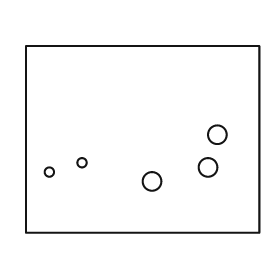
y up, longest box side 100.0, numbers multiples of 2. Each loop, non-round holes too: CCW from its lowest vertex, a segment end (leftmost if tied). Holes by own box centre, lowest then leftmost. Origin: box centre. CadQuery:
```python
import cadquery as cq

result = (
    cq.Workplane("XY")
    .moveTo(-50.0, -40.0)
    .lineTo(50.0, -40.0)
    .lineTo(50.0, 40.0)
    .lineTo(-50.0, 40.0)
    .close()
    .moveTo(4.0, -18.0)
    .circle(4.0)
    .moveTo(-40.0, -14.0)
    .circle(2.0)
    .moveTo(28.0, -12.0)
    .circle(4.0)
    .moveTo(-26.0, -10.0)
    .circle(2.0)
    .moveTo(32.0, 2.0)
    .circle(4.0)
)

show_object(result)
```